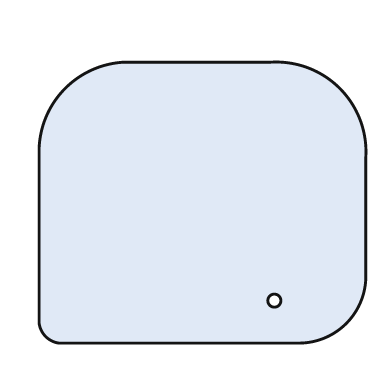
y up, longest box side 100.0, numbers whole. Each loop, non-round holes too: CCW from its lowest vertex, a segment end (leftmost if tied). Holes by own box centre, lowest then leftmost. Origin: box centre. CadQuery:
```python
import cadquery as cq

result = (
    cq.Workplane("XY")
    .moveTo(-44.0, -43.0)
    .lineTo(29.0, -43.0)
    .threePointArc((44.0, -37.0), (50.0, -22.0))
    .lineTo(50.0, 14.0)
    .threePointArc((42.0, 35.0), (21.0, 43.0))
    .lineTo(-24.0, 43.0)
    .threePointArc((-42.0, 35.0), (-50.0, 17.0))
    .lineTo(-50.0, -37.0)
    .threePointArc((-48.0, -41.0), (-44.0, -43.0))
    .close()
    .moveTo(22.0, -30.0)
    .circle(2.0)
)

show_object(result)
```